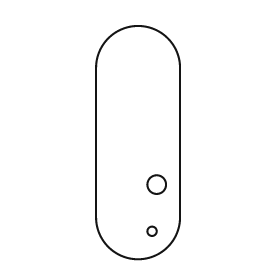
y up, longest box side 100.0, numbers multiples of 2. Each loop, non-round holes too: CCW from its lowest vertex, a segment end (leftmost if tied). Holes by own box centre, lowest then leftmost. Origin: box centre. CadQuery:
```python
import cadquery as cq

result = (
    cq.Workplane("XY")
    .moveTo(-18.0, -32.0)
    .threePointArc((0.0, -50.0), (18.0, -32.0))
    .lineTo(18.0, 32.0)
    .threePointArc((0.0, 50.0), (-18.0, 32.0))
    .close()
    .moveTo(6.0, -38.0)
    .circle(2.0)
    .moveTo(8.0, -18.0)
    .circle(4.0)
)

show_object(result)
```